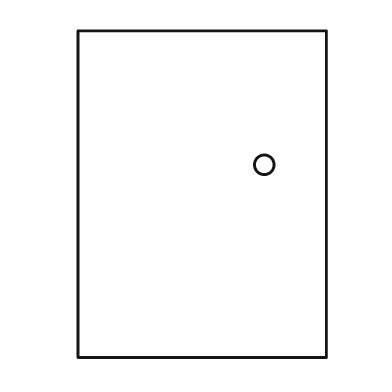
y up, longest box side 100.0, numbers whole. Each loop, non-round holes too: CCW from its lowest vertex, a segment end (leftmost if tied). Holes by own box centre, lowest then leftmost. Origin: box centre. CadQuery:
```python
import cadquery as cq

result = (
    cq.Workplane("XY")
    .moveTo(-38.0, -50.0)
    .lineTo(38.0, -50.0)
    .lineTo(38.0, 50.0)
    .lineTo(-38.0, 50.0)
    .close()
    .moveTo(19.0, 9.0)
    .circle(3.0)
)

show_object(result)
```